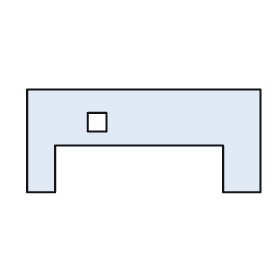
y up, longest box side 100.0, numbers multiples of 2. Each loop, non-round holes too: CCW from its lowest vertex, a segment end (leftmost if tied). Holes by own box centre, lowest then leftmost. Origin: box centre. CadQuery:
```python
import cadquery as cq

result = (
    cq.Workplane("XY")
    .moveTo(-50.0, -22.0)
    .lineTo(-38.0, -22.0)
    .lineTo(-38.0, -2.0)
    .lineTo(34.0, -2.0)
    .lineTo(34.0, -22.0)
    .lineTo(50.0, -22.0)
    .lineTo(50.0, 22.0)
    .lineTo(-50.0, 22.0)
    .close()
    .moveTo(-24.0, 4.0)
    .lineTo(-16.0, 4.0)
    .lineTo(-16.0, 12.0)
    .lineTo(-24.0, 12.0)
    .close()
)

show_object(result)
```